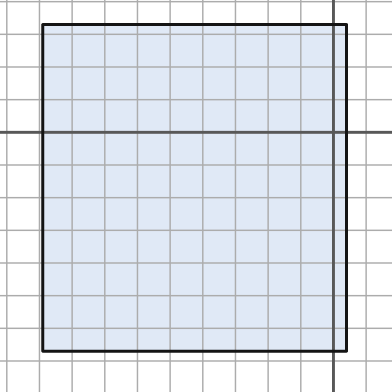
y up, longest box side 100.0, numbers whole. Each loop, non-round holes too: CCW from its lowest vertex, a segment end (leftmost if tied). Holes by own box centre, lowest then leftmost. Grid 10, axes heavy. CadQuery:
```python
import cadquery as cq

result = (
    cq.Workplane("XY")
    .moveTo(-89.0, -67.0)
    .lineTo(4.0, -67.0)
    .lineTo(4.0, 33.0)
    .lineTo(-89.0, 33.0)
    .close()
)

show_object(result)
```